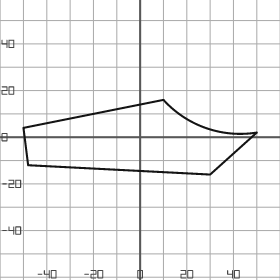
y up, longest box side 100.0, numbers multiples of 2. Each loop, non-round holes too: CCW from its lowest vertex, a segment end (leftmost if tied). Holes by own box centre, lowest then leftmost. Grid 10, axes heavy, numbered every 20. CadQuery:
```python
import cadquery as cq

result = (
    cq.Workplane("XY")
    .moveTo(30.0, -16.0)
    .lineTo(50.0, 2.0)
    .threePointArc((28.0, 4.0), (10.0, 16.0))
    .lineTo(-50.0, 4.0)
    .lineTo(-48.0, -12.0)
    .close()
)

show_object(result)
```